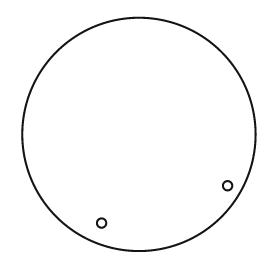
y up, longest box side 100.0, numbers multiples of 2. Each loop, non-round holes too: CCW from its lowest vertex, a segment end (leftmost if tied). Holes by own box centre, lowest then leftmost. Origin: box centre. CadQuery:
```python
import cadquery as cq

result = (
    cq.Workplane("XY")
    .moveTo(0.0, 0.0)
    .circle(50.0)
    .moveTo(-16.0, -38.0)
    .circle(2.0)
    .moveTo(38.0, -22.0)
    .circle(2.0)
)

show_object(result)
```